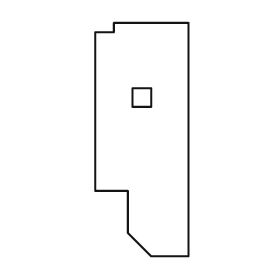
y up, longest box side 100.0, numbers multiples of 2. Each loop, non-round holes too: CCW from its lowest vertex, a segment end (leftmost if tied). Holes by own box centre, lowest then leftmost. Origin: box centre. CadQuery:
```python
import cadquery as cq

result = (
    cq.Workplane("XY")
    .moveTo(4.0, -50.0)
    .lineTo(20.0, -50.0)
    .lineTo(20.0, 50.0)
    .lineTo(-12.0, 50.0)
    .lineTo(-12.0, 46.0)
    .lineTo(-20.0, 46.0)
    .lineTo(-20.0, -22.0)
    .lineTo(-6.0, -22.0)
    .lineTo(-6.0, -40.0)
    .close()
    .moveTo(-4.0, 14.0)
    .lineTo(4.0, 14.0)
    .lineTo(4.0, 22.0)
    .lineTo(-4.0, 22.0)
    .close()
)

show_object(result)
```